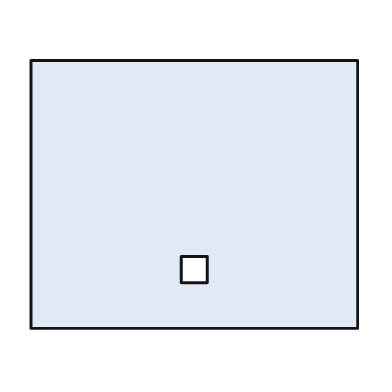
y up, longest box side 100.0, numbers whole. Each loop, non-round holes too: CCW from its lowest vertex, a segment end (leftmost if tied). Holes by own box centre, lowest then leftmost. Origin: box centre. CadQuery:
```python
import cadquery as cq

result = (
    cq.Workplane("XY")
    .moveTo(-50.0, -41.0)
    .lineTo(50.0, -41.0)
    .lineTo(50.0, 41.0)
    .lineTo(-50.0, 41.0)
    .close()
    .moveTo(-4.0, -27.0)
    .lineTo(4.0, -27.0)
    .lineTo(4.0, -19.0)
    .lineTo(-4.0, -19.0)
    .close()
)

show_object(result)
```